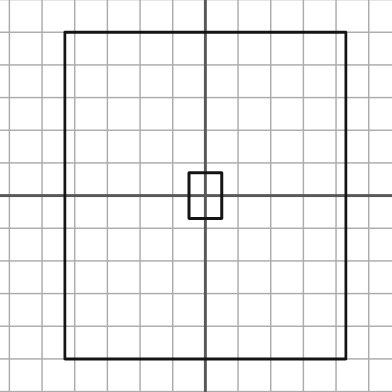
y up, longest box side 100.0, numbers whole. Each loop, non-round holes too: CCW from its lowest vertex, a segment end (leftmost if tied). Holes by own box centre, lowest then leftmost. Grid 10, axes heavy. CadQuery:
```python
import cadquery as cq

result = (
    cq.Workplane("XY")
    .moveTo(-43.0, -50.0)
    .lineTo(43.0, -50.0)
    .lineTo(43.0, 50.0)
    .lineTo(-43.0, 50.0)
    .close()
    .moveTo(-5.0, -7.0)
    .lineTo(5.0, -7.0)
    .lineTo(5.0, 7.0)
    .lineTo(-5.0, 7.0)
    .close()
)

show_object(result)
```